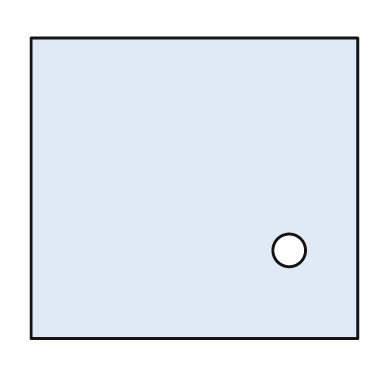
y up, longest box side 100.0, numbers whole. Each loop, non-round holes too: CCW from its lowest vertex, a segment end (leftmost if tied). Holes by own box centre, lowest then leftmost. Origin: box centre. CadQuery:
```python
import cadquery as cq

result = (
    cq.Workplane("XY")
    .moveTo(-50.0, -46.0)
    .lineTo(50.0, -46.0)
    .lineTo(50.0, 46.0)
    .lineTo(-50.0, 46.0)
    .close()
    .moveTo(29.0, -19.0)
    .circle(5.0)
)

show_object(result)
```